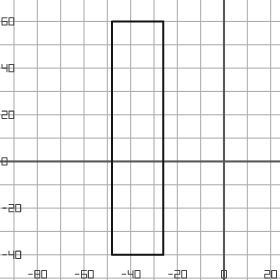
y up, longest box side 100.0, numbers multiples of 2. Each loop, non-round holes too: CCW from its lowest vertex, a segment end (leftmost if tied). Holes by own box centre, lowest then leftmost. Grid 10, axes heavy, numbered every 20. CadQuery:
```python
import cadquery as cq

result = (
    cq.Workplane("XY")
    .moveTo(-48.0, -40.0)
    .lineTo(-26.0, -40.0)
    .lineTo(-26.0, 60.0)
    .lineTo(-48.0, 60.0)
    .close()
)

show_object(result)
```